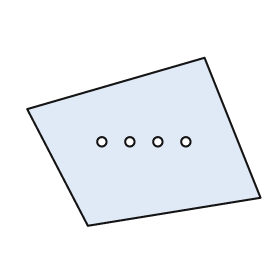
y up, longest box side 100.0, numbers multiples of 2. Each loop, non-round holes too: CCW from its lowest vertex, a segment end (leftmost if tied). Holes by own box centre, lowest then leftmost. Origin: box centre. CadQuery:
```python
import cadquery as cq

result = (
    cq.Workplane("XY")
    .moveTo(-24.0, -36.0)
    .lineTo(50.0, -24.0)
    .lineTo(26.0, 36.0)
    .lineTo(-50.0, 14.0)
    .close()
    .moveTo(-18.0, 0.0)
    .circle(2.0)
    .moveTo(-6.0, 0.0)
    .circle(2.0)
    .moveTo(6.0, 0.0)
    .circle(2.0)
    .moveTo(18.0, 0.0)
    .circle(2.0)
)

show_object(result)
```